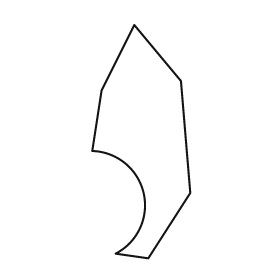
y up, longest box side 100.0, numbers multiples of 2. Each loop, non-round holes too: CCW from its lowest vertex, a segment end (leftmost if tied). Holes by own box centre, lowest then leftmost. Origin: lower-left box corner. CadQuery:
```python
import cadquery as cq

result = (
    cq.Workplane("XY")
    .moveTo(24.0, 0.0)
    .lineTo(42.0, 28.0)
    .lineTo(38.0, 76.0)
    .lineTo(18.0, 100.0)
    .lineTo(4.0, 72.0)
    .lineTo(0.0, 46.0)
    .threePointArc((22.0, 28.0), (10.0, 2.0))
    .close()
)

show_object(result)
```